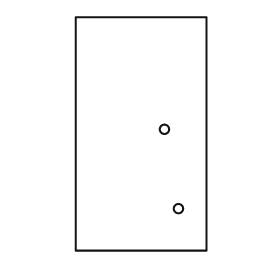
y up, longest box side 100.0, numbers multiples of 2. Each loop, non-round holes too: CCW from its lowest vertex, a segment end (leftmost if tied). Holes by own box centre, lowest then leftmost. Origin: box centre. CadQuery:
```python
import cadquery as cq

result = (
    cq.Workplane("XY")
    .moveTo(-28.0, -50.0)
    .lineTo(28.0, -50.0)
    .lineTo(28.0, 50.0)
    .lineTo(-28.0, 50.0)
    .close()
    .moveTo(16.0, -32.0)
    .circle(2.0)
    .moveTo(10.0, 2.0)
    .circle(2.0)
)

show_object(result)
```